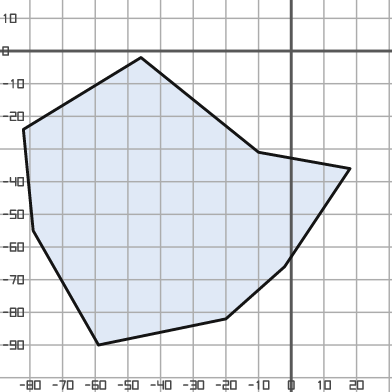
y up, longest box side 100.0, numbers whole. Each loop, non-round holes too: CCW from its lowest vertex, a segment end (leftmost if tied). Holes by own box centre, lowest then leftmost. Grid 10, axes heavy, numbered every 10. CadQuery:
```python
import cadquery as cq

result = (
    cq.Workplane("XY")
    .moveTo(-59.0, -90.0)
    .lineTo(-20.0, -82.0)
    .lineTo(-2.0, -66.0)
    .lineTo(18.0, -36.0)
    .lineTo(-10.0, -31.0)
    .lineTo(-46.0, -2.0)
    .lineTo(-82.0, -24.0)
    .lineTo(-79.0, -55.0)
    .close()
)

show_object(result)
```